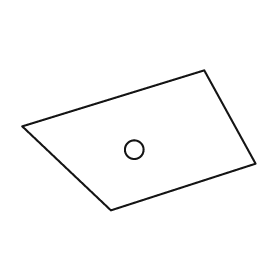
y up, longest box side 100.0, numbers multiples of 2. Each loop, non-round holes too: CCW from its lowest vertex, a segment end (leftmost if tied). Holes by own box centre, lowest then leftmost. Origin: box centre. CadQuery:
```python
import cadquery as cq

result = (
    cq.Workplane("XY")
    .moveTo(-12.0, -30.0)
    .lineTo(50.0, -10.0)
    .lineTo(28.0, 30.0)
    .lineTo(-50.0, 6.0)
    .close()
    .moveTo(-2.0, -4.0)
    .circle(4.0)
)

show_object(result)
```